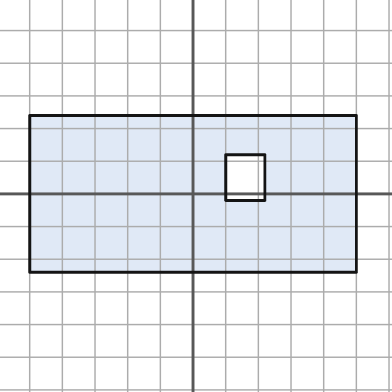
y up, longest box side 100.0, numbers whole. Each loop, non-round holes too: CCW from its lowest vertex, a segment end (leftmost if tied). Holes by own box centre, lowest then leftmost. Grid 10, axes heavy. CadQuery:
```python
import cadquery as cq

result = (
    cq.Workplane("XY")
    .moveTo(-50.0, -24.0)
    .lineTo(50.0, -24.0)
    .lineTo(50.0, 24.0)
    .lineTo(-50.0, 24.0)
    .close()
    .moveTo(10.0, -2.0)
    .lineTo(22.0, -2.0)
    .lineTo(22.0, 12.0)
    .lineTo(10.0, 12.0)
    .close()
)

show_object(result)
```